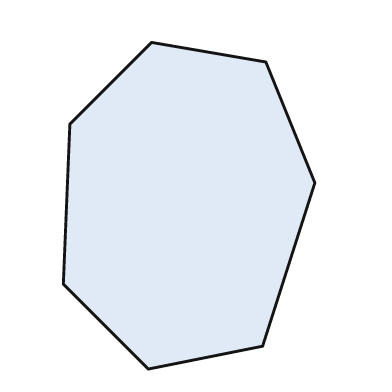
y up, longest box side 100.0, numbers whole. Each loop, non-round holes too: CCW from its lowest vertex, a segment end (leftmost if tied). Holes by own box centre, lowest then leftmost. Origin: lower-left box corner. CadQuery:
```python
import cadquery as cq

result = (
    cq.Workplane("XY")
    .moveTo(26.0, 0.0)
    .lineTo(61.0, 7.0)
    .lineTo(77.0, 57.0)
    .lineTo(62.0, 94.0)
    .lineTo(27.0, 100.0)
    .lineTo(2.0, 75.0)
    .lineTo(0.0, 26.0)
    .close()
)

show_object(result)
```